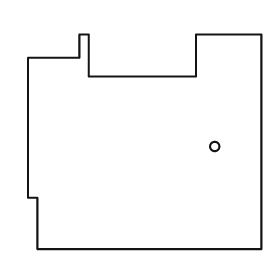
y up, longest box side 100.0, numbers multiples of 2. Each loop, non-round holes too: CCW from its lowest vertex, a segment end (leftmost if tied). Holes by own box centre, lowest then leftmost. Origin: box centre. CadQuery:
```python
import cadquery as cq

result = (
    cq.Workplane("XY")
    .moveTo(-46.0, -46.0)
    .lineTo(50.0, -46.0)
    .lineTo(50.0, 46.0)
    .lineTo(22.0, 46.0)
    .lineTo(22.0, 28.0)
    .lineTo(-24.0, 28.0)
    .lineTo(-24.0, 46.0)
    .lineTo(-28.0, 46.0)
    .lineTo(-28.0, 36.0)
    .lineTo(-50.0, 36.0)
    .lineTo(-50.0, -24.0)
    .lineTo(-46.0, -24.0)
    .close()
    .moveTo(30.0, -2.0)
    .circle(2.0)
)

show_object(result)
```